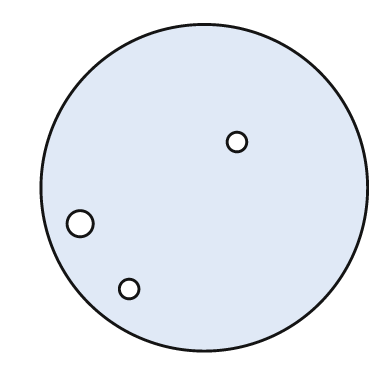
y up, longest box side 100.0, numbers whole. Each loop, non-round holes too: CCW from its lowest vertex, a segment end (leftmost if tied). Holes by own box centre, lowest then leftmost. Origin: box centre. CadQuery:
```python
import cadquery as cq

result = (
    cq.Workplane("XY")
    .moveTo(0.0, 0.0)
    .circle(50.0)
    .moveTo(-23.0, -31.0)
    .circle(3.0)
    .moveTo(-38.0, -11.0)
    .circle(4.0)
    .moveTo(10.0, 14.0)
    .circle(3.0)
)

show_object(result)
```